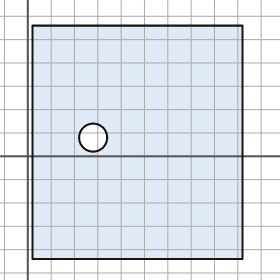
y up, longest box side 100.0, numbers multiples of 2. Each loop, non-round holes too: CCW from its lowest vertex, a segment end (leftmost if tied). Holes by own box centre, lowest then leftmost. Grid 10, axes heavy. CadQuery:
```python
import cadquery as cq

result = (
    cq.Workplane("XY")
    .moveTo(2.0, -44.0)
    .lineTo(92.0, -44.0)
    .lineTo(92.0, 56.0)
    .lineTo(2.0, 56.0)
    .close()
    .moveTo(28.0, 8.0)
    .circle(6.0)
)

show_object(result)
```